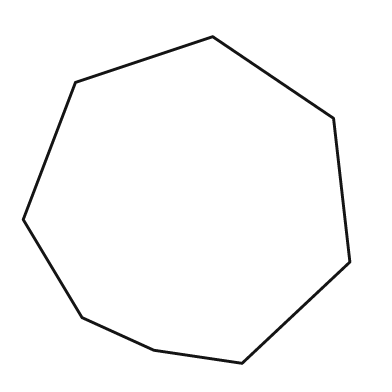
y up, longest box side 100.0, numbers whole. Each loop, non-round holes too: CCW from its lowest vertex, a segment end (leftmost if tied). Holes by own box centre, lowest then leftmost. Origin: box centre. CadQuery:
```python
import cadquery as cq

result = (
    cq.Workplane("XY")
    .moveTo(17.0, -50.0)
    .lineTo(50.0, -19.0)
    .lineTo(45.0, 25.0)
    .lineTo(8.0, 50.0)
    .lineTo(-34.0, 36.0)
    .lineTo(-50.0, -6.0)
    .lineTo(-32.0, -36.0)
    .lineTo(-10.0, -46.0)
    .close()
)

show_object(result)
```